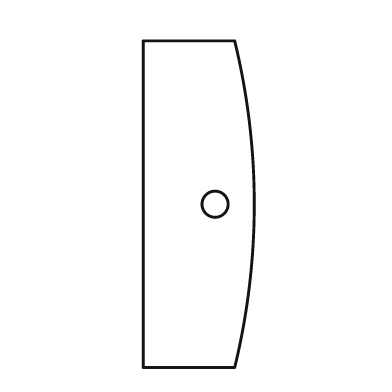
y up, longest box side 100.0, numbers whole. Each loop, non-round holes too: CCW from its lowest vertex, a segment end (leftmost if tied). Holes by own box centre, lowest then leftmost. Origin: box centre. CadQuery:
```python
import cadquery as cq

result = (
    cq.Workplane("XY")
    .moveTo(-17.0, -50.0)
    .lineTo(11.0, -50.0)
    .threePointArc((17.0, 0.0), (11.0, 50.0))
    .lineTo(-17.0, 50.0)
    .close()
    .moveTo(5.0, 0.0)
    .circle(4.0)
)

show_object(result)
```